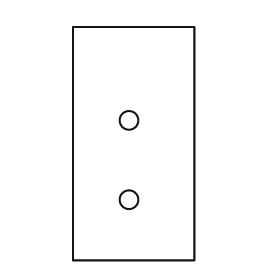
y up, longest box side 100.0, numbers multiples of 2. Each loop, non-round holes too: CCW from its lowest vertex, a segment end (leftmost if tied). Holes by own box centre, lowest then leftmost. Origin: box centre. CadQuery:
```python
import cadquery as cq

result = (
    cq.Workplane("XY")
    .moveTo(-26.0, -50.0)
    .lineTo(26.0, -50.0)
    .lineTo(26.0, 50.0)
    .lineTo(-26.0, 50.0)
    .close()
    .moveTo(-2.0, -24.0)
    .circle(4.0)
    .moveTo(-2.0, 10.0)
    .circle(4.0)
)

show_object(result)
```